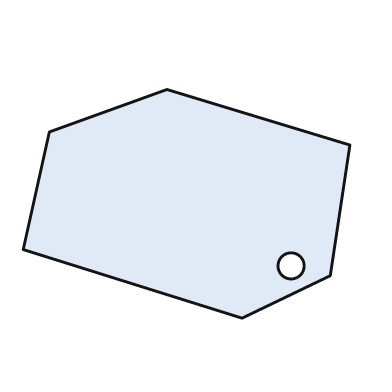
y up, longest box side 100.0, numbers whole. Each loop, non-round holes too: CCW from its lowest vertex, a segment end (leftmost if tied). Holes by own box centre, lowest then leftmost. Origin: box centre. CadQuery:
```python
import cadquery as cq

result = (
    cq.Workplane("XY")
    .moveTo(17.0, -35.0)
    .lineTo(44.0, -22.0)
    .lineTo(50.0, 18.0)
    .lineTo(-6.0, 35.0)
    .lineTo(-42.0, 22.0)
    .lineTo(-50.0, -14.0)
    .close()
    .moveTo(32.0, -19.0)
    .circle(4.0)
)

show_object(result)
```